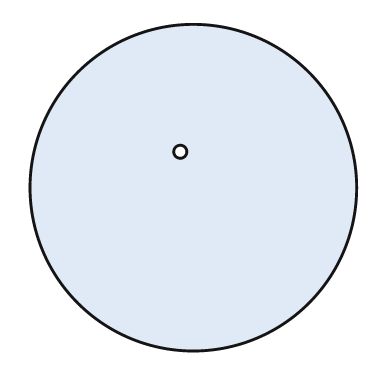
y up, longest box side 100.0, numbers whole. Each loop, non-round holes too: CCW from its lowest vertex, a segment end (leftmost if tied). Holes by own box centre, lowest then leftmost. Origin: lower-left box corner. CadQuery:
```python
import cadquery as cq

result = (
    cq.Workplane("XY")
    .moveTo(50.0, 50.0)
    .circle(50.0)
    .moveTo(46.0, 61.0)
    .circle(2.0)
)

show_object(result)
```